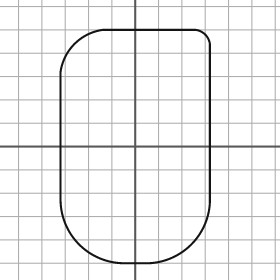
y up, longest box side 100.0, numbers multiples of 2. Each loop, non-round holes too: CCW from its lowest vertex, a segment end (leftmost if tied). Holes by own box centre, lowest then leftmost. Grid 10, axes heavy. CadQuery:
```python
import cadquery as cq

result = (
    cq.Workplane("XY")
    .moveTo(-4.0, -50.0)
    .lineTo(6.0, -50.0)
    .threePointArc((24.0, -42.0), (32.0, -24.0))
    .lineTo(32.0, 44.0)
    .threePointArc((30.0, 48.0), (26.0, 50.0))
    .lineTo(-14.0, 50.0)
    .threePointArc((-26.0, 44.0), (-32.0, 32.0))
    .lineTo(-32.0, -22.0)
    .threePointArc((-24.0, -42.0), (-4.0, -50.0))
    .close()
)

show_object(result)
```